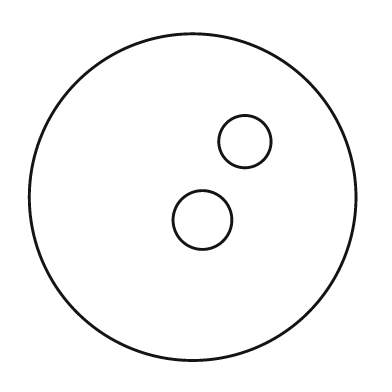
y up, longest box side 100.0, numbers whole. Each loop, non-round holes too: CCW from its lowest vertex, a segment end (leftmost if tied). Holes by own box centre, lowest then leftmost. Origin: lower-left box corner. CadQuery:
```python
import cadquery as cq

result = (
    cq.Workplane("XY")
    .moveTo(50.0, 50.0)
    .circle(50.0)
    .moveTo(53.0, 43.0)
    .circle(9.0)
    .moveTo(66.0, 67.0)
    .circle(8.0)
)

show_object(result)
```